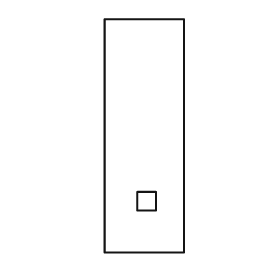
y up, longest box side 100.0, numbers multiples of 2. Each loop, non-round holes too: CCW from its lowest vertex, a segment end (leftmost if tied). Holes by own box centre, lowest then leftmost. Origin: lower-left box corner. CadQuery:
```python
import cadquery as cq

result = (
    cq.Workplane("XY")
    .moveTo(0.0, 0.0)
    .lineTo(34.0, 0.0)
    .lineTo(34.0, 100.0)
    .lineTo(0.0, 100.0)
    .close()
    .moveTo(14.0, 18.0)
    .lineTo(22.0, 18.0)
    .lineTo(22.0, 26.0)
    .lineTo(14.0, 26.0)
    .close()
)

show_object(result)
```